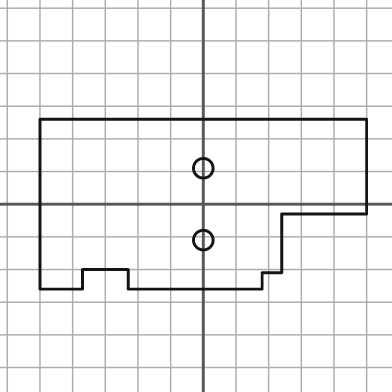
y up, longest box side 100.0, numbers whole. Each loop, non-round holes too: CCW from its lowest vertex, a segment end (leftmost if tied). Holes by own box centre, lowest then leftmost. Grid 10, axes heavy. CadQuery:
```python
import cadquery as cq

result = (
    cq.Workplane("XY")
    .moveTo(-50.0, -26.0)
    .lineTo(-37.0, -26.0)
    .lineTo(-37.0, -20.0)
    .lineTo(-23.0, -20.0)
    .lineTo(-23.0, -26.0)
    .lineTo(18.0, -26.0)
    .lineTo(18.0, -21.0)
    .lineTo(24.0, -21.0)
    .lineTo(24.0, -3.0)
    .lineTo(50.0, -3.0)
    .lineTo(50.0, 26.0)
    .lineTo(-50.0, 26.0)
    .close()
    .moveTo(0.0, -11.0)
    .circle(3.0)
    .moveTo(0.0, 11.0)
    .circle(3.0)
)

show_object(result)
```